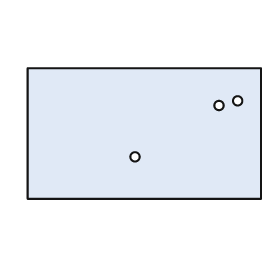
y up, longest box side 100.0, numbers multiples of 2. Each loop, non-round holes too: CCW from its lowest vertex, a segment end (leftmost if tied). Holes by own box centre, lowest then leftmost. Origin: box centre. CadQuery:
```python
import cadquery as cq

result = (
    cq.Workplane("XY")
    .moveTo(-50.0, -28.0)
    .lineTo(50.0, -28.0)
    .lineTo(50.0, 28.0)
    .lineTo(-50.0, 28.0)
    .close()
    .moveTo(-4.0, -10.0)
    .circle(2.0)
    .moveTo(32.0, 12.0)
    .circle(2.0)
    .moveTo(40.0, 14.0)
    .circle(2.0)
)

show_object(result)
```